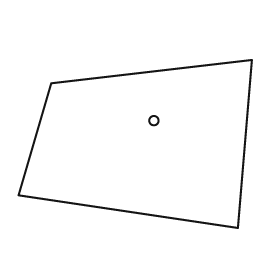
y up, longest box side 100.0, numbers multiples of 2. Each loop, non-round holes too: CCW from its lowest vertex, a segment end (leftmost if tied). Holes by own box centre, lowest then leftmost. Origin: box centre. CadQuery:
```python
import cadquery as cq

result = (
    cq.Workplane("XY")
    .moveTo(44.0, -36.0)
    .lineTo(50.0, 36.0)
    .lineTo(-36.0, 26.0)
    .lineTo(-50.0, -22.0)
    .close()
    .moveTo(8.0, 10.0)
    .circle(2.0)
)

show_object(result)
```